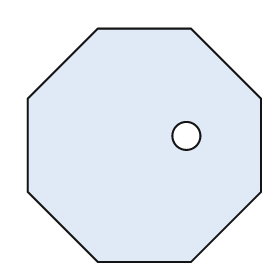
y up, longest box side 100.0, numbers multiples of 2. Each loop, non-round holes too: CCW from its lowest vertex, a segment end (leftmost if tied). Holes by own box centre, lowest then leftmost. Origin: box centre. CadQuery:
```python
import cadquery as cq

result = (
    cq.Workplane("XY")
    .moveTo(-20.0, -50.0)
    .lineTo(20.0, -50.0)
    .lineTo(50.0, -20.0)
    .lineTo(50.0, 20.0)
    .lineTo(20.0, 50.0)
    .lineTo(-20.0, 50.0)
    .lineTo(-50.0, 20.0)
    .lineTo(-50.0, -20.0)
    .close()
    .moveTo(18.0, 4.0)
    .circle(6.0)
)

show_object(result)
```